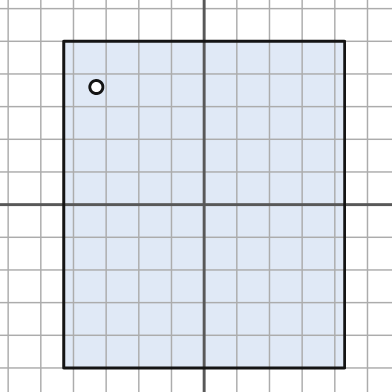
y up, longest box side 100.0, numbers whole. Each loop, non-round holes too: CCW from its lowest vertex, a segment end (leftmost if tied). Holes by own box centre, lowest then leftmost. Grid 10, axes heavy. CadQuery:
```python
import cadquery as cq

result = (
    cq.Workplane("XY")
    .moveTo(-43.0, -50.0)
    .lineTo(43.0, -50.0)
    .lineTo(43.0, 50.0)
    .lineTo(-43.0, 50.0)
    .close()
    .moveTo(-33.0, 36.0)
    .circle(2.0)
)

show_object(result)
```